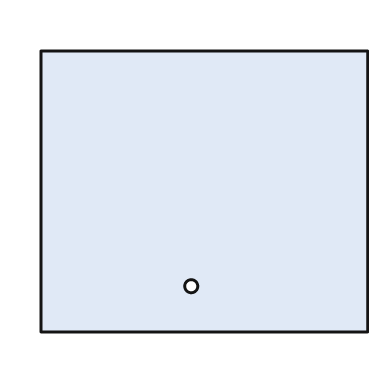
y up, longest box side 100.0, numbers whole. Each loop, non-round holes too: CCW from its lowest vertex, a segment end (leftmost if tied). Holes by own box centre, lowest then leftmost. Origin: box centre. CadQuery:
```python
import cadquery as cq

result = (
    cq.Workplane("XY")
    .moveTo(-50.0, -43.0)
    .lineTo(50.0, -43.0)
    .lineTo(50.0, 43.0)
    .lineTo(-50.0, 43.0)
    .close()
    .moveTo(-4.0, -29.0)
    .circle(2.0)
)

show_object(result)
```